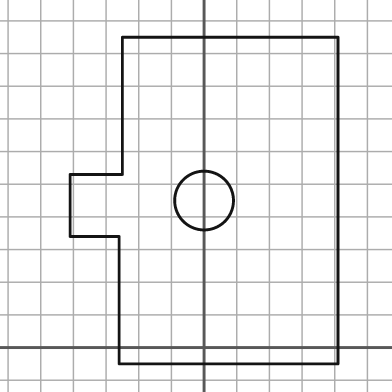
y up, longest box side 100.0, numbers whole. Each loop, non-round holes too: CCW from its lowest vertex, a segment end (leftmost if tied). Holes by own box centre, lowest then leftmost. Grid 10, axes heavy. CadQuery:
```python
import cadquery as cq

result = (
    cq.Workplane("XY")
    .moveTo(-26.0, -5.0)
    .lineTo(41.0, -5.0)
    .lineTo(41.0, 95.0)
    .lineTo(-25.0, 95.0)
    .lineTo(-25.0, 53.0)
    .lineTo(-41.0, 53.0)
    .lineTo(-41.0, 34.0)
    .lineTo(-26.0, 34.0)
    .close()
    .moveTo(0.0, 45.0)
    .circle(9.0)
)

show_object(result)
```